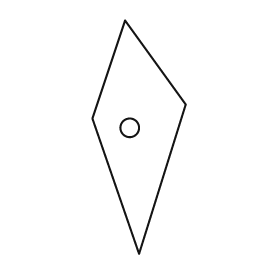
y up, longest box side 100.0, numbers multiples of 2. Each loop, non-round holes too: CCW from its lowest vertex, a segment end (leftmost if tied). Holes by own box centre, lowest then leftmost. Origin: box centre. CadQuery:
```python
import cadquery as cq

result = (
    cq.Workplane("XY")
    .moveTo(0.0, -50.0)
    .lineTo(20.0, 14.0)
    .lineTo(-6.0, 50.0)
    .lineTo(-20.0, 8.0)
    .close()
    .moveTo(-4.0, 4.0)
    .circle(4.0)
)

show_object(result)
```